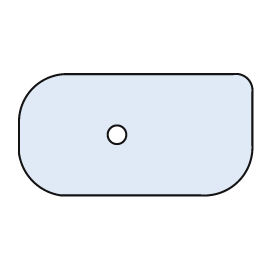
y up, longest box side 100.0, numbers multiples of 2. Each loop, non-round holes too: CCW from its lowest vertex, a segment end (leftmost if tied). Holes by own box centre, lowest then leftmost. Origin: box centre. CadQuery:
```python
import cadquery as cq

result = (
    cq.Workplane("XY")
    .moveTo(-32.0, -26.0)
    .lineTo(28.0, -26.0)
    .threePointArc((44.0, -20.0), (50.0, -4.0))
    .lineTo(50.0, 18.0)
    .threePointArc((48.0, 24.0), (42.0, 26.0))
    .lineTo(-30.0, 26.0)
    .threePointArc((-44.0, 20.0), (-50.0, 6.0))
    .lineTo(-50.0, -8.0)
    .threePointArc((-44.0, -20.0), (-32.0, -26.0))
    .close()
    .moveTo(-8.0, 0.0)
    .circle(4.0)
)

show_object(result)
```